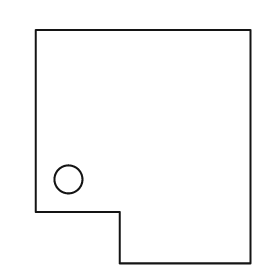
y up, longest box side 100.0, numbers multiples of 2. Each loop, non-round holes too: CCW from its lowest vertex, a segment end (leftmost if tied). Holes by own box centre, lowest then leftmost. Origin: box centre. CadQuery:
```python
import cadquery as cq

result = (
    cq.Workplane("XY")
    .moveTo(-10.0, -50.0)
    .lineTo(46.0, -50.0)
    .lineTo(46.0, 50.0)
    .lineTo(-46.0, 50.0)
    .lineTo(-46.0, -28.0)
    .lineTo(-10.0, -28.0)
    .close()
    .moveTo(-32.0, -14.0)
    .circle(6.0)
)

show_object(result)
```